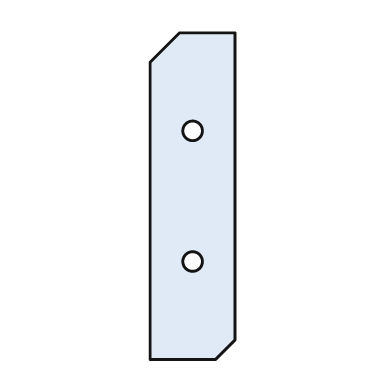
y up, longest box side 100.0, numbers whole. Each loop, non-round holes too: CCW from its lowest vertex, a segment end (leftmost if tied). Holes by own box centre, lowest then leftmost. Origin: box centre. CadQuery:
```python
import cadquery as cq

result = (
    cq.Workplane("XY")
    .moveTo(-13.0, -50.0)
    .lineTo(7.0, -50.0)
    .lineTo(13.0, -44.0)
    .lineTo(13.0, 50.0)
    .lineTo(-4.0, 50.0)
    .lineTo(-13.0, 41.0)
    .close()
    .moveTo(0.0, -20.0)
    .circle(3.0)
    .moveTo(0.0, 20.0)
    .circle(3.0)
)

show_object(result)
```